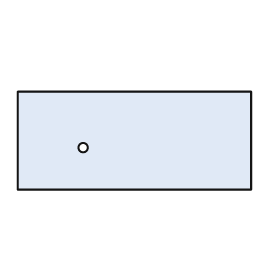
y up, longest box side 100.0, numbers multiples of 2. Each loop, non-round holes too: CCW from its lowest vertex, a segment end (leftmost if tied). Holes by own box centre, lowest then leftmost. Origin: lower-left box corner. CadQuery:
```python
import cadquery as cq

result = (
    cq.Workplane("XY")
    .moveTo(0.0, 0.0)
    .lineTo(100.0, 0.0)
    .lineTo(100.0, 42.0)
    .lineTo(0.0, 42.0)
    .close()
    .moveTo(28.0, 18.0)
    .circle(2.0)
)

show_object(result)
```